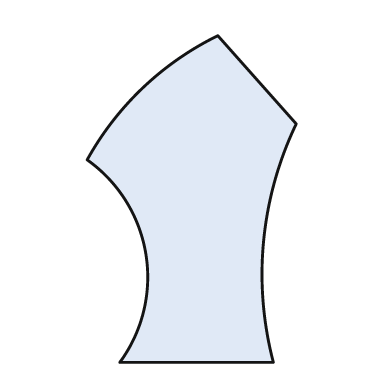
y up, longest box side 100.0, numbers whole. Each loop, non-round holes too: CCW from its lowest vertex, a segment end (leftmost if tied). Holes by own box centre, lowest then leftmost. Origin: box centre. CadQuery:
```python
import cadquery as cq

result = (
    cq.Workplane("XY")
    .moveTo(-22.0, -50.0)
    .lineTo(25.0, -50.0)
    .threePointArc((22.0, -13.0), (32.0, 23.0))
    .lineTo(8.0, 50.0)
    .threePointArc((-15.0, 34.0), (-32.0, 12.0))
    .threePointArc((-14.0, -17.0), (-22.0, -50.0))
    .close()
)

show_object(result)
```